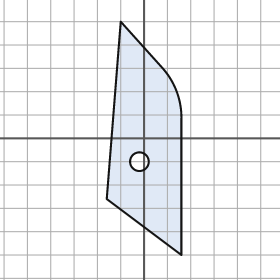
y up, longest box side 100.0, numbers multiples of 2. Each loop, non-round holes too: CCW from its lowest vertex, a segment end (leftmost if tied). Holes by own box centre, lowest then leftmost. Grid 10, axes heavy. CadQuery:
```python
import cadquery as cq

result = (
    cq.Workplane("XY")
    .moveTo(16.0, -50.0)
    .lineTo(16.0, 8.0)
    .threePointArc((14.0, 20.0), (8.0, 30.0))
    .lineTo(-10.0, 50.0)
    .lineTo(-16.0, -26.0)
    .close()
    .moveTo(-2.0, -10.0)
    .circle(4.0)
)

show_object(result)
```